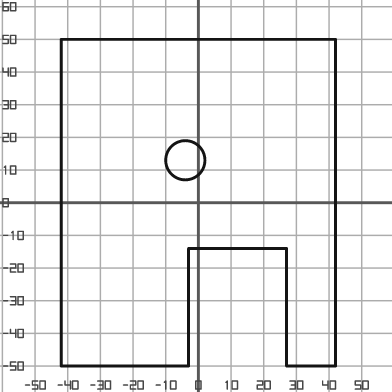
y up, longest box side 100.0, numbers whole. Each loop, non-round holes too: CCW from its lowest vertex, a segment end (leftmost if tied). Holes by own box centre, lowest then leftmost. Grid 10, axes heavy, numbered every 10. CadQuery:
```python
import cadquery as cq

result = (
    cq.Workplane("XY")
    .moveTo(-42.0, -50.0)
    .lineTo(-3.0, -50.0)
    .lineTo(-3.0, -14.0)
    .lineTo(27.0, -14.0)
    .lineTo(27.0, -50.0)
    .lineTo(42.0, -50.0)
    .lineTo(42.0, 50.0)
    .lineTo(-42.0, 50.0)
    .close()
    .moveTo(-4.0, 13.0)
    .circle(6.0)
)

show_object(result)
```